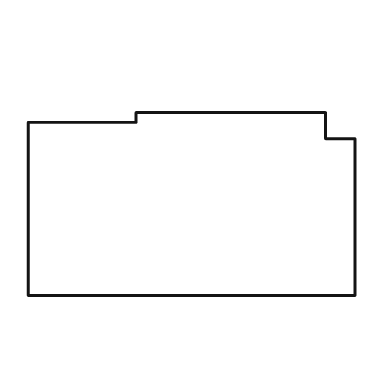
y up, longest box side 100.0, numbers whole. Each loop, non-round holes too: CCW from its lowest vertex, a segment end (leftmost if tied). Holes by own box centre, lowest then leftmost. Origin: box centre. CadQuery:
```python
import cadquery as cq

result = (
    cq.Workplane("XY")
    .moveTo(-50.0, -28.0)
    .lineTo(50.0, -28.0)
    .lineTo(50.0, 20.0)
    .lineTo(41.0, 20.0)
    .lineTo(41.0, 28.0)
    .lineTo(-17.0, 28.0)
    .lineTo(-17.0, 25.0)
    .lineTo(-50.0, 25.0)
    .close()
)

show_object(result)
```